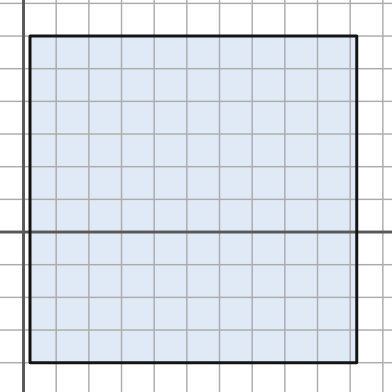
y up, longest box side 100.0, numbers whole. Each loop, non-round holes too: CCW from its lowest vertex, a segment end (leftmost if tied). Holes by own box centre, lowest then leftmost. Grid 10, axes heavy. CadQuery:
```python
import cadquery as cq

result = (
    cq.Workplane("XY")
    .moveTo(2.0, -40.0)
    .lineTo(102.0, -40.0)
    .lineTo(102.0, 60.0)
    .lineTo(2.0, 60.0)
    .close()
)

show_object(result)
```